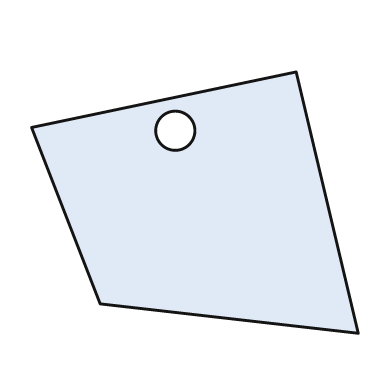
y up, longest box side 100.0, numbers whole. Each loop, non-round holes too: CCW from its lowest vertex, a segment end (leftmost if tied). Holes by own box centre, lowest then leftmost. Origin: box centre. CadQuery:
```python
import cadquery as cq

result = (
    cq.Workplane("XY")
    .moveTo(50.0, -40.0)
    .lineTo(31.0, 40.0)
    .lineTo(-50.0, 23.0)
    .lineTo(-29.0, -31.0)
    .close()
    .moveTo(-6.0, 22.0)
    .circle(6.0)
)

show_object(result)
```